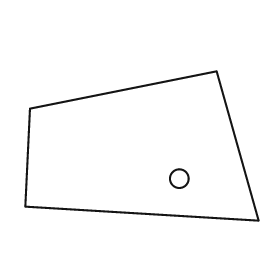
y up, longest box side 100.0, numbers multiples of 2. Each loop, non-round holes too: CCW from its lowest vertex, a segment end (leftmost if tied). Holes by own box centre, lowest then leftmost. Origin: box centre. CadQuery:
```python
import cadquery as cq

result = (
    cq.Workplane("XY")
    .moveTo(50.0, -32.0)
    .lineTo(32.0, 32.0)
    .lineTo(-48.0, 16.0)
    .lineTo(-50.0, -26.0)
    .close()
    .moveTo(16.0, -14.0)
    .circle(4.0)
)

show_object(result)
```